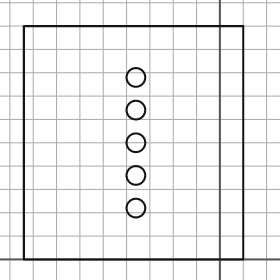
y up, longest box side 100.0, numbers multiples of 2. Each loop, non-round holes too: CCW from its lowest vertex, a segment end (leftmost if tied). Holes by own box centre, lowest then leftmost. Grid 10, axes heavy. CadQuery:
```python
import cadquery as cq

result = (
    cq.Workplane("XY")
    .moveTo(-84.0, 0.0)
    .lineTo(10.0, 0.0)
    .lineTo(10.0, 100.0)
    .lineTo(-84.0, 100.0)
    .close()
    .moveTo(-36.0, 22.0)
    .circle(4.0)
    .moveTo(-36.0, 36.0)
    .circle(4.0)
    .moveTo(-36.0, 50.0)
    .circle(4.0)
    .moveTo(-36.0, 64.0)
    .circle(4.0)
    .moveTo(-36.0, 78.0)
    .circle(4.0)
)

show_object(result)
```